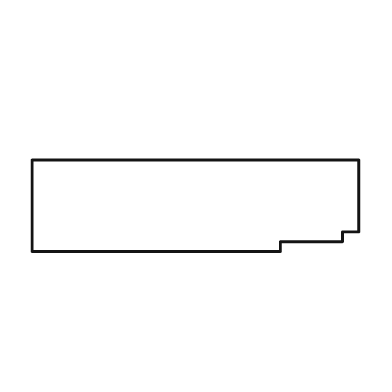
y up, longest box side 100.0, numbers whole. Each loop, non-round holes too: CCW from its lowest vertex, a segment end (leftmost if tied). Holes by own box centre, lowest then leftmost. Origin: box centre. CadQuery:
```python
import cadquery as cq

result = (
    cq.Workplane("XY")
    .moveTo(-50.0, -14.0)
    .lineTo(26.0, -14.0)
    .lineTo(26.0, -11.0)
    .lineTo(45.0, -11.0)
    .lineTo(45.0, -8.0)
    .lineTo(50.0, -8.0)
    .lineTo(50.0, 14.0)
    .lineTo(-50.0, 14.0)
    .close()
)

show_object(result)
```